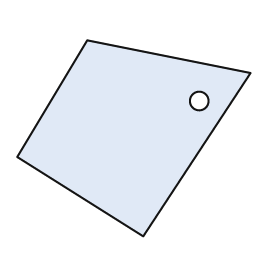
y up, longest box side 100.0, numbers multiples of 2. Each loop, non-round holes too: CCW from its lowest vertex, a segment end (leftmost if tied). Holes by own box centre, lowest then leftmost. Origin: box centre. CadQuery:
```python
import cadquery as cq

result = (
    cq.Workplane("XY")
    .moveTo(4.0, -42.0)
    .lineTo(50.0, 28.0)
    .lineTo(-20.0, 42.0)
    .lineTo(-50.0, -8.0)
    .close()
    .moveTo(28.0, 16.0)
    .circle(4.0)
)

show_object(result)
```